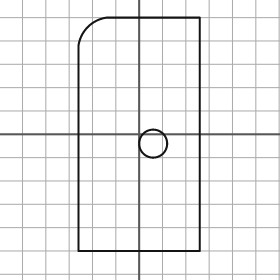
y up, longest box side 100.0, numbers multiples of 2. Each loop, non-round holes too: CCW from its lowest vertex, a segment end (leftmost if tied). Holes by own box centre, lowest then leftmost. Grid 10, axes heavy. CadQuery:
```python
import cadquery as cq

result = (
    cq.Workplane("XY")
    .moveTo(-26.0, -50.0)
    .lineTo(26.0, -50.0)
    .lineTo(26.0, 50.0)
    .lineTo(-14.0, 50.0)
    .threePointArc((-22.0, 46.0), (-26.0, 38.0))
    .close()
    .moveTo(6.0, -4.0)
    .circle(6.0)
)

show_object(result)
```